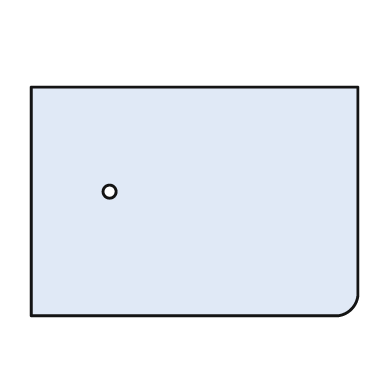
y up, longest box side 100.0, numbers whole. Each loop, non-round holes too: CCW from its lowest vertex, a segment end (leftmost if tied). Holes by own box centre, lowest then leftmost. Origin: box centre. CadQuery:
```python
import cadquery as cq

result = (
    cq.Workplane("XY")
    .moveTo(-50.0, -35.0)
    .lineTo(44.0, -35.0)
    .threePointArc((48.0, -33.0), (50.0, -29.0))
    .lineTo(50.0, 35.0)
    .lineTo(-50.0, 35.0)
    .close()
    .moveTo(-26.0, 3.0)
    .circle(2.0)
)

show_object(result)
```